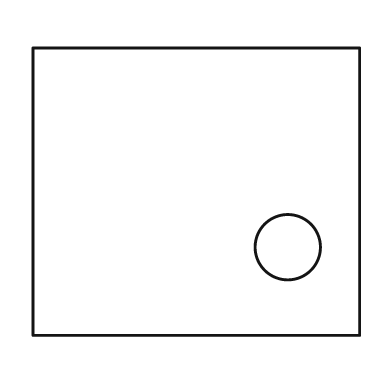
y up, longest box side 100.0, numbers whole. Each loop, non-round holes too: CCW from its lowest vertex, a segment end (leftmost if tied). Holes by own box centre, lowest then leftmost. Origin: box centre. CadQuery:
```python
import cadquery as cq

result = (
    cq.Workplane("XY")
    .moveTo(-50.0, -44.0)
    .lineTo(50.0, -44.0)
    .lineTo(50.0, 44.0)
    .lineTo(-50.0, 44.0)
    .close()
    .moveTo(28.0, -17.0)
    .circle(10.0)
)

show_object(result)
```